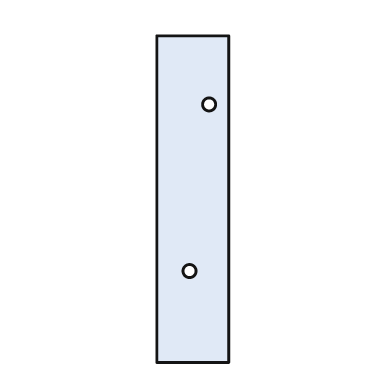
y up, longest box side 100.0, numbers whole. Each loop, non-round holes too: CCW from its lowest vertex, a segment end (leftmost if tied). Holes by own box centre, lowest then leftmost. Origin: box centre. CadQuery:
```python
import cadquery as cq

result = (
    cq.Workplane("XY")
    .moveTo(-11.0, -50.0)
    .lineTo(11.0, -50.0)
    .lineTo(11.0, 50.0)
    .lineTo(-11.0, 50.0)
    .close()
    .moveTo(-1.0, -22.0)
    .circle(2.0)
    .moveTo(5.0, 29.0)
    .circle(2.0)
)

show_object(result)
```